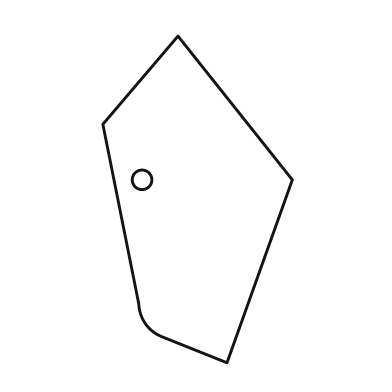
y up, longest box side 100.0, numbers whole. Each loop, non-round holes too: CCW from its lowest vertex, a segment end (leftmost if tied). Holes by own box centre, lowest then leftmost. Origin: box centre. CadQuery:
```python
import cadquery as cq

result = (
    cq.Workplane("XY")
    .moveTo(9.0, -50.0)
    .lineTo(29.0, 6.0)
    .lineTo(-6.0, 50.0)
    .lineTo(-29.0, 23.0)
    .lineTo(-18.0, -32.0)
    .threePointArc((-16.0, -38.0), (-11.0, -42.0))
    .close()
    .moveTo(-17.0, 6.0)
    .circle(3.0)
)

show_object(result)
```